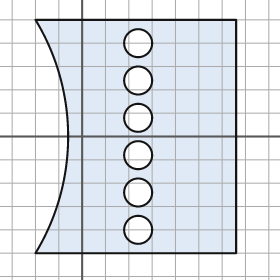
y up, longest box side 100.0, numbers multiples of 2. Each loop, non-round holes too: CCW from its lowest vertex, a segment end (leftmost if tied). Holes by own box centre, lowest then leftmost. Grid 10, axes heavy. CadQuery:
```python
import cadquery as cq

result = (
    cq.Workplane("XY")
    .moveTo(-20.0, -50.0)
    .lineTo(66.0, -50.0)
    .lineTo(66.0, 50.0)
    .lineTo(-20.0, 50.0)
    .threePointArc((-6.0, 0.0), (-20.0, -50.0))
    .close()
    .moveTo(24.0, -40.0)
    .circle(6.0)
    .moveTo(24.0, -24.0)
    .circle(6.0)
    .moveTo(24.0, -8.0)
    .circle(6.0)
    .moveTo(24.0, 8.0)
    .circle(6.0)
    .moveTo(24.0, 24.0)
    .circle(6.0)
    .moveTo(24.0, 40.0)
    .circle(6.0)
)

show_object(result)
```